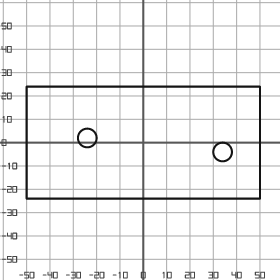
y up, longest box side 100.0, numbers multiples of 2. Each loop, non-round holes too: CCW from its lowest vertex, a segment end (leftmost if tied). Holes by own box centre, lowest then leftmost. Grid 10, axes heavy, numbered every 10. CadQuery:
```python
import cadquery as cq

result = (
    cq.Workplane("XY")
    .moveTo(-50.0, -24.0)
    .lineTo(50.0, -24.0)
    .lineTo(50.0, 24.0)
    .lineTo(-50.0, 24.0)
    .close()
    .moveTo(34.0, -4.0)
    .circle(4.0)
    .moveTo(-24.0, 2.0)
    .circle(4.0)
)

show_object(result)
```